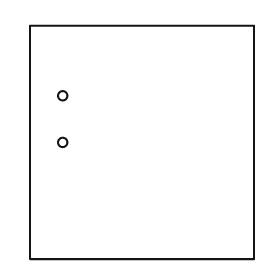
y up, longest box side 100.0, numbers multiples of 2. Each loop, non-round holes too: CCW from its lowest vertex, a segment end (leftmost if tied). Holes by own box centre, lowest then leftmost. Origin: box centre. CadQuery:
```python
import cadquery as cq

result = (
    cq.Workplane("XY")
    .moveTo(-48.0, -50.0)
    .lineTo(48.0, -50.0)
    .lineTo(48.0, 50.0)
    .lineTo(-48.0, 50.0)
    .close()
    .moveTo(-34.0, 0.0)
    .circle(2.0)
    .moveTo(-34.0, 20.0)
    .circle(2.0)
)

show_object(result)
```